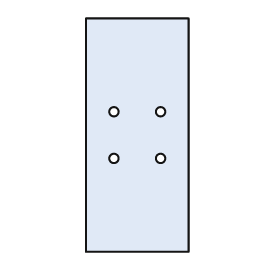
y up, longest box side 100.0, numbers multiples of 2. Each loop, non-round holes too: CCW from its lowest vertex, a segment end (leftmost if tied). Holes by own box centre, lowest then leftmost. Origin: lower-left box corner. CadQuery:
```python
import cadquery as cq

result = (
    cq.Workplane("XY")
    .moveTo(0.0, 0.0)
    .lineTo(44.0, 0.0)
    .lineTo(44.0, 100.0)
    .lineTo(0.0, 100.0)
    .close()
    .moveTo(12.0, 40.0)
    .circle(2.0)
    .moveTo(32.0, 40.0)
    .circle(2.0)
    .moveTo(12.0, 60.0)
    .circle(2.0)
    .moveTo(32.0, 60.0)
    .circle(2.0)
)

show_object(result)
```